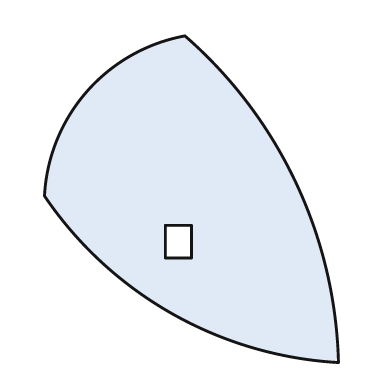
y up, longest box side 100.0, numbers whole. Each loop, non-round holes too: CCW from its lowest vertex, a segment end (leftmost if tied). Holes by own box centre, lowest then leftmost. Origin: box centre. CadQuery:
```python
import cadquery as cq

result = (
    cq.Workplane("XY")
    .moveTo(45.0, -50.0)
    .threePointArc((32.0, 5.0), (-2.0, 50.0))
    .threePointArc((-32.0, 33.0), (-45.0, 1.0))
    .threePointArc((-6.0, -35.0), (45.0, -50.0))
    .close()
    .moveTo(-8.0, -18.0)
    .lineTo(0.0, -18.0)
    .lineTo(0.0, -8.0)
    .lineTo(-8.0, -8.0)
    .close()
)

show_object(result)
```